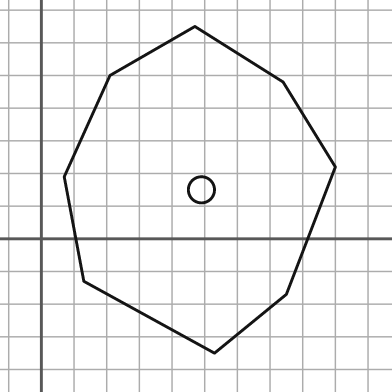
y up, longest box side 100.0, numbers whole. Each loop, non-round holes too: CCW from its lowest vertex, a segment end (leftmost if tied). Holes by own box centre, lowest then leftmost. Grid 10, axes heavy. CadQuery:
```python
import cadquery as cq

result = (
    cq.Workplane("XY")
    .moveTo(53.0, -35.0)
    .lineTo(75.0, -17.0)
    .lineTo(90.0, 22.0)
    .lineTo(74.0, 48.0)
    .lineTo(47.0, 65.0)
    .lineTo(21.0, 50.0)
    .lineTo(7.0, 19.0)
    .lineTo(13.0, -13.0)
    .close()
    .moveTo(49.0, 15.0)
    .circle(4.0)
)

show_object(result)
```